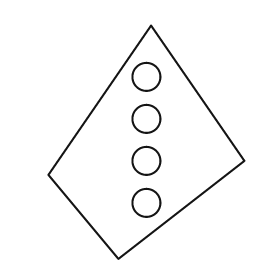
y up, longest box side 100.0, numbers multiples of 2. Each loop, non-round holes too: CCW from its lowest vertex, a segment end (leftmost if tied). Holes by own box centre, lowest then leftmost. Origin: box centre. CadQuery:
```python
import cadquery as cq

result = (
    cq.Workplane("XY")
    .moveTo(-12.0, -50.0)
    .lineTo(42.0, -8.0)
    .lineTo(2.0, 50.0)
    .lineTo(-42.0, -14.0)
    .close()
    .moveTo(0.0, -26.0)
    .circle(6.0)
    .moveTo(0.0, -8.0)
    .circle(6.0)
    .moveTo(0.0, 10.0)
    .circle(6.0)
    .moveTo(0.0, 28.0)
    .circle(6.0)
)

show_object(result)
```